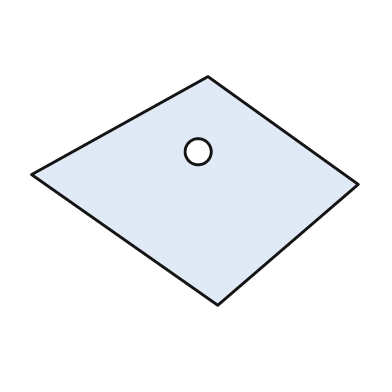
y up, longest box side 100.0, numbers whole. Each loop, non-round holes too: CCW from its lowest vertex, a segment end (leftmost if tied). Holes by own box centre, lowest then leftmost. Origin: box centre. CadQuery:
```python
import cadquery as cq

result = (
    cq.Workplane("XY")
    .moveTo(7.0, -35.0)
    .lineTo(50.0, 2.0)
    .lineTo(4.0, 35.0)
    .lineTo(-50.0, 5.0)
    .close()
    .moveTo(1.0, 12.0)
    .circle(4.0)
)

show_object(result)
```